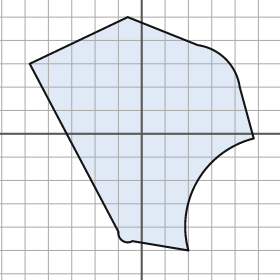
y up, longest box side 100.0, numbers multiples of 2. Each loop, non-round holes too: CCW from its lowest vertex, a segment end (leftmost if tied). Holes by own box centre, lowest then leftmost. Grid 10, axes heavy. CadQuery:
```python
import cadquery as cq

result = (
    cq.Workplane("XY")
    .moveTo(20.0, -50.0)
    .threePointArc((24.0, -20.0), (48.0, -2.0))
    .lineTo(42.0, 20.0)
    .threePointArc((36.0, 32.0), (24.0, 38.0))
    .lineTo(-6.0, 50.0)
    .lineTo(-48.0, 30.0)
    .lineTo(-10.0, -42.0)
    .threePointArc((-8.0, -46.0), (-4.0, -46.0))
    .close()
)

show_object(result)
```